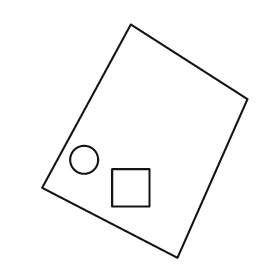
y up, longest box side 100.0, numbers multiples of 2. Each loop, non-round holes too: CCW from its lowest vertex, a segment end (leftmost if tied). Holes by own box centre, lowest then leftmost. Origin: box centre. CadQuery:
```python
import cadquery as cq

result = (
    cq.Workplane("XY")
    .moveTo(14.0, -50.0)
    .lineTo(44.0, 18.0)
    .lineTo(-6.0, 50.0)
    .lineTo(-44.0, -20.0)
    .close()
    .moveTo(-14.0, -28.0)
    .lineTo(2.0, -28.0)
    .lineTo(2.0, -12.0)
    .lineTo(-14.0, -12.0)
    .close()
    .moveTo(-26.0, -8.0)
    .circle(6.0)
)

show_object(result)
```